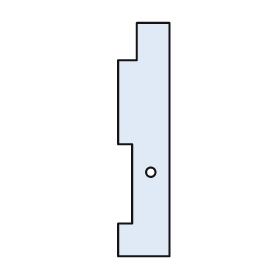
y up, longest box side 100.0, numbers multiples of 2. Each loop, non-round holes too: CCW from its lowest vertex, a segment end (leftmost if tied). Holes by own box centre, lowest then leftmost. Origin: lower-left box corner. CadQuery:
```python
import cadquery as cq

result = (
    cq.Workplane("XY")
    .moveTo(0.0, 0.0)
    .lineTo(22.0, 0.0)
    .lineTo(22.0, 100.0)
    .lineTo(8.0, 100.0)
    .lineTo(8.0, 84.0)
    .lineTo(0.0, 84.0)
    .lineTo(0.0, 48.0)
    .lineTo(6.0, 48.0)
    .lineTo(6.0, 14.0)
    .lineTo(0.0, 14.0)
    .close()
    .moveTo(14.0, 36.0)
    .circle(2.0)
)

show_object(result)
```